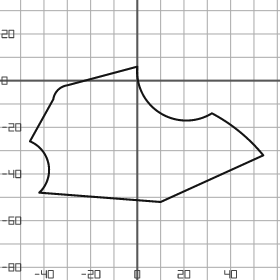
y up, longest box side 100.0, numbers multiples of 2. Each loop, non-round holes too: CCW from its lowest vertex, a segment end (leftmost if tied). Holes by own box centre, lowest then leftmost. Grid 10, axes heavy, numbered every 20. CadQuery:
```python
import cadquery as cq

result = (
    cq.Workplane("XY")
    .moveTo(10.0, -52.0)
    .lineTo(54.0, -32.0)
    .threePointArc((44.0, -22.0), (32.0, -14.0))
    .threePointArc((10.0, -14.0), (0.0, 6.0))
    .lineTo(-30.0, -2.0)
    .threePointArc((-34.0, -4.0), (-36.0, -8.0))
    .lineTo(-46.0, -26.0)
    .threePointArc((-38.0, -36.0), (-42.0, -48.0))
    .close()
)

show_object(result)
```